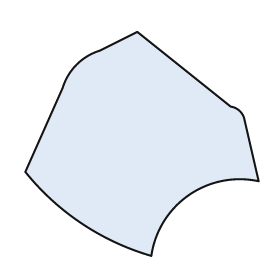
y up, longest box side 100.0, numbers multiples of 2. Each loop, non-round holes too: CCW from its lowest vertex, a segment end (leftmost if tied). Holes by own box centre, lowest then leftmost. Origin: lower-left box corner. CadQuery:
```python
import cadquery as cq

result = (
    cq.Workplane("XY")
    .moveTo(54.0, 0.0)
    .threePointArc((70.0, 26.0), (100.0, 32.0))
    .lineTo(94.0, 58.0)
    .threePointArc((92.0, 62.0), (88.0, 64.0))
    .lineTo(48.0, 96.0)
    .lineTo(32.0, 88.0)
    .threePointArc((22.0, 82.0), (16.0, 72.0))
    .lineTo(0.0, 36.0)
    .threePointArc((24.0, 14.0), (54.0, 0.0))
    .close()
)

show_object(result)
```